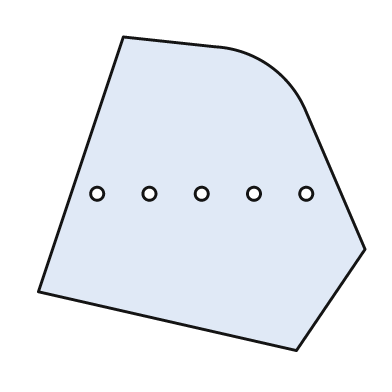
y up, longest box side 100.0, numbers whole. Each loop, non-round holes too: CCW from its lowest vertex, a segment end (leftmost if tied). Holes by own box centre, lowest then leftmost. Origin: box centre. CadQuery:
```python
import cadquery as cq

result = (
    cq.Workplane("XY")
    .moveTo(29.0, -48.0)
    .lineTo(50.0, -17.0)
    .lineTo(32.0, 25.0)
    .threePointArc((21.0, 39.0), (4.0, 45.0))
    .lineTo(-24.0, 48.0)
    .lineTo(-50.0, -30.0)
    .close()
    .moveTo(-32.0, 0.0)
    .circle(2.0)
    .moveTo(-16.0, 0.0)
    .circle(2.0)
    .moveTo(0.0, 0.0)
    .circle(2.0)
    .moveTo(16.0, 0.0)
    .circle(2.0)
    .moveTo(32.0, 0.0)
    .circle(2.0)
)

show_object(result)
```